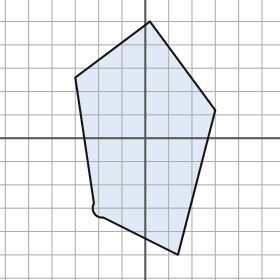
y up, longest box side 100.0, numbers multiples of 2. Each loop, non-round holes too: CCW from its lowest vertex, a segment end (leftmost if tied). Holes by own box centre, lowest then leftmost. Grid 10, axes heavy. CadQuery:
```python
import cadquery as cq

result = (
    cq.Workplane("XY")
    .moveTo(14.0, -50.0)
    .lineTo(30.0, 12.0)
    .lineTo(2.0, 50.0)
    .lineTo(-30.0, 26.0)
    .lineTo(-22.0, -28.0)
    .threePointArc((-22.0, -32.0), (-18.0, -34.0))
    .close()
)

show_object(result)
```